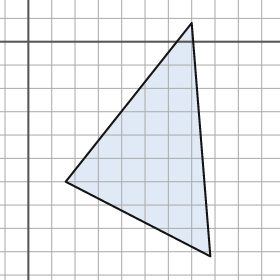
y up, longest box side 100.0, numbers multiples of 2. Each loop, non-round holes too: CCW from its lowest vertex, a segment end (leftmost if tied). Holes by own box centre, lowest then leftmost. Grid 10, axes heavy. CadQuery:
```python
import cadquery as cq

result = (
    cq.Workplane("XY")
    .moveTo(78.0, -92.0)
    .lineTo(70.0, 8.0)
    .lineTo(16.0, -60.0)
    .close()
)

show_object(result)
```